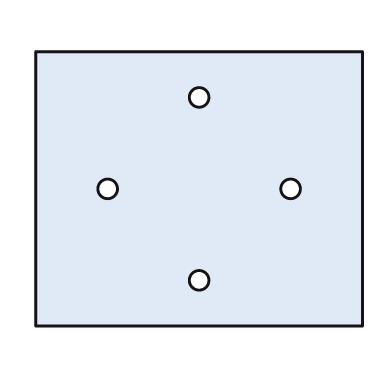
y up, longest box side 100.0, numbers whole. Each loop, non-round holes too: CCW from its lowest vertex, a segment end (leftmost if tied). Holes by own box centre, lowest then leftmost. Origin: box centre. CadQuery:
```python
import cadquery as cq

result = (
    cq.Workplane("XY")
    .moveTo(-50.0, -42.0)
    .lineTo(50.0, -42.0)
    .lineTo(50.0, 42.0)
    .lineTo(-50.0, 42.0)
    .close()
    .moveTo(0.0, -28.0)
    .circle(3.0)
    .moveTo(-28.0, 0.0)
    .circle(3.0)
    .moveTo(28.0, 0.0)
    .circle(3.0)
    .moveTo(0.0, 28.0)
    .circle(3.0)
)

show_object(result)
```